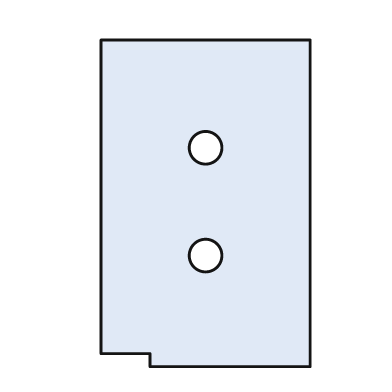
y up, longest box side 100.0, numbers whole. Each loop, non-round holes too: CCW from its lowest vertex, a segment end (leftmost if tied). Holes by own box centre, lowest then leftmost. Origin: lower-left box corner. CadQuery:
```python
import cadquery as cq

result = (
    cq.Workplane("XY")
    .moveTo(15.0, 0.0)
    .lineTo(64.0, 0.0)
    .lineTo(64.0, 100.0)
    .lineTo(0.0, 100.0)
    .lineTo(0.0, 4.0)
    .lineTo(15.0, 4.0)
    .close()
    .moveTo(32.0, 34.0)
    .circle(5.0)
    .moveTo(32.0, 67.0)
    .circle(5.0)
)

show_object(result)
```